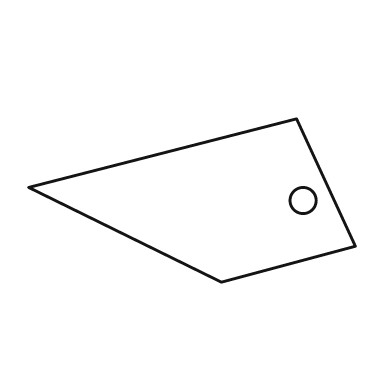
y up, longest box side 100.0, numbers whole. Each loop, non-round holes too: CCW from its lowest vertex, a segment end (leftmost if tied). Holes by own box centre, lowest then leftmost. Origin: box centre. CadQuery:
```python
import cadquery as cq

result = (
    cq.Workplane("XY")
    .moveTo(9.0, -25.0)
    .lineTo(50.0, -14.0)
    .lineTo(32.0, 25.0)
    .lineTo(-50.0, 4.0)
    .close()
    .moveTo(34.0, 0.0)
    .circle(4.0)
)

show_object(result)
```